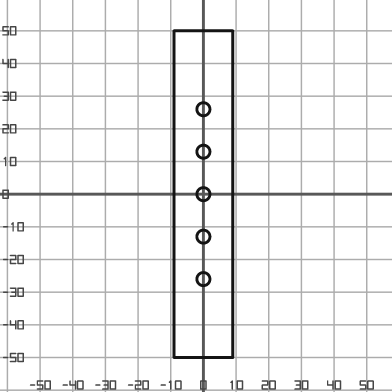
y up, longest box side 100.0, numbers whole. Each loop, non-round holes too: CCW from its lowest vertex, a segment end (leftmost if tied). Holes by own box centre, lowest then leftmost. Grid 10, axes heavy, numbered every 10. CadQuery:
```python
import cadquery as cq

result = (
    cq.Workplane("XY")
    .moveTo(-9.0, -50.0)
    .lineTo(9.0, -50.0)
    .lineTo(9.0, 50.0)
    .lineTo(-9.0, 50.0)
    .close()
    .moveTo(0.0, -26.0)
    .circle(2.0)
    .moveTo(0.0, -13.0)
    .circle(2.0)
    .moveTo(0.0, 0.0)
    .circle(2.0)
    .moveTo(0.0, 13.0)
    .circle(2.0)
    .moveTo(0.0, 26.0)
    .circle(2.0)
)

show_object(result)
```